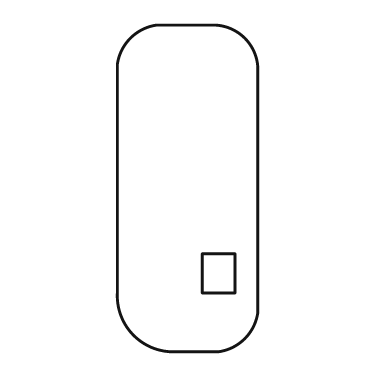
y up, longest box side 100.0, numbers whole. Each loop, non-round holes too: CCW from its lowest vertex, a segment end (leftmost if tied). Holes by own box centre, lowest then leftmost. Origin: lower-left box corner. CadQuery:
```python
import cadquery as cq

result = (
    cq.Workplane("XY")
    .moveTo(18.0, 0.0)
    .lineTo(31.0, 0.0)
    .threePointArc((39.0, 4.0), (43.0, 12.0))
    .lineTo(43.0, 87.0)
    .threePointArc((39.0, 96.0), (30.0, 100.0))
    .lineTo(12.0, 100.0)
    .threePointArc((4.0, 96.0), (0.0, 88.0))
    .lineTo(0.0, 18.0)
    .threePointArc((5.0, 5.0), (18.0, 0.0))
    .close()
    .moveTo(26.0, 18.0)
    .lineTo(36.0, 18.0)
    .lineTo(36.0, 30.0)
    .lineTo(26.0, 30.0)
    .close()
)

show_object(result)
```